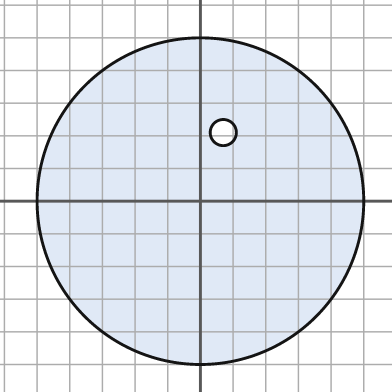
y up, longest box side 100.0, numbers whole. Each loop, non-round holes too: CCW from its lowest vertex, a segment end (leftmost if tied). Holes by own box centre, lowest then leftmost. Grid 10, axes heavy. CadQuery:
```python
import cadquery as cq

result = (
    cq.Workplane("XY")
    .moveTo(0.0, 0.0)
    .circle(50.0)
    .moveTo(7.0, 21.0)
    .circle(4.0)
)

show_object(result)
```